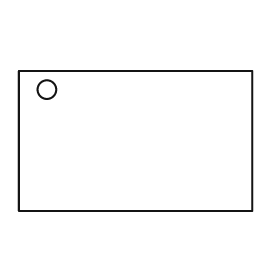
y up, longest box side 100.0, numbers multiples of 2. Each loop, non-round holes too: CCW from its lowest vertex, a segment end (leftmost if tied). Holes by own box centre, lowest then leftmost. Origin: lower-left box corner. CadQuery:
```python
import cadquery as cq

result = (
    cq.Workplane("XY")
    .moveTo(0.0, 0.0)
    .lineTo(100.0, 0.0)
    .lineTo(100.0, 60.0)
    .lineTo(0.0, 60.0)
    .close()
    .moveTo(12.0, 52.0)
    .circle(4.0)
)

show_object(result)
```